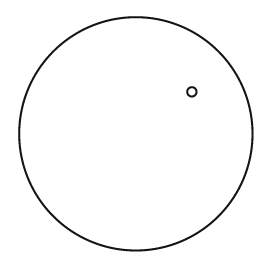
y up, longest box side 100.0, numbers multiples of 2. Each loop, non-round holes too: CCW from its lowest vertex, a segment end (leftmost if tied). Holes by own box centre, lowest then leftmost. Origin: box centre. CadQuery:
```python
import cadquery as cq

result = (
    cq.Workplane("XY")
    .moveTo(0.0, 0.0)
    .circle(50.0)
    .moveTo(24.0, 18.0)
    .circle(2.0)
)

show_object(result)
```